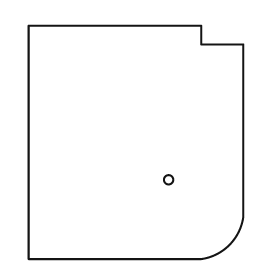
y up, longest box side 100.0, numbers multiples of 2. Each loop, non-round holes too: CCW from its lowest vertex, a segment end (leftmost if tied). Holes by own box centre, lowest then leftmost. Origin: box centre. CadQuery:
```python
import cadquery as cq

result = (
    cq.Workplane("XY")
    .moveTo(-46.0, -50.0)
    .lineTo(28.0, -50.0)
    .threePointArc((40.0, -44.0), (46.0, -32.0))
    .lineTo(46.0, 42.0)
    .lineTo(28.0, 42.0)
    .lineTo(28.0, 50.0)
    .lineTo(-46.0, 50.0)
    .close()
    .moveTo(14.0, -16.0)
    .circle(2.0)
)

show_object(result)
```